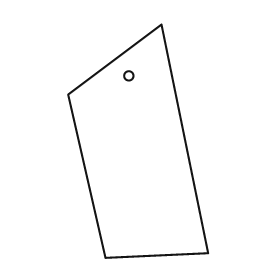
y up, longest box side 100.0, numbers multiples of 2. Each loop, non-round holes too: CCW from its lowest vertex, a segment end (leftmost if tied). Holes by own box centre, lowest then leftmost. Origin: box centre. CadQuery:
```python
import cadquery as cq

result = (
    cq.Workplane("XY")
    .moveTo(-14.0, -50.0)
    .lineTo(30.0, -48.0)
    .lineTo(10.0, 50.0)
    .lineTo(-30.0, 20.0)
    .close()
    .moveTo(-4.0, 28.0)
    .circle(2.0)
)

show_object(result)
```